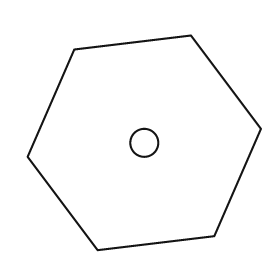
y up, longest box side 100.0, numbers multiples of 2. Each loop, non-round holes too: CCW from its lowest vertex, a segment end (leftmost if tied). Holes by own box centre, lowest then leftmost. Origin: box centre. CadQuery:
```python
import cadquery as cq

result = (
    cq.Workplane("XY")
    .moveTo(-20.0, -46.0)
    .lineTo(30.0, -40.0)
    .lineTo(50.0, 6.0)
    .lineTo(20.0, 46.0)
    .lineTo(-30.0, 40.0)
    .lineTo(-50.0, -6.0)
    .close()
    .moveTo(0.0, 0.0)
    .circle(6.0)
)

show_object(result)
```